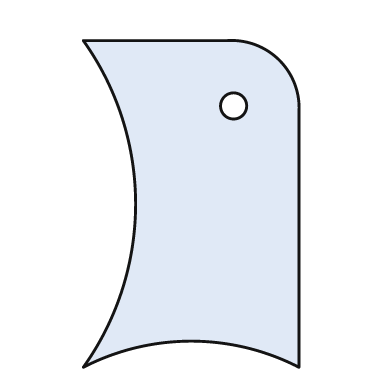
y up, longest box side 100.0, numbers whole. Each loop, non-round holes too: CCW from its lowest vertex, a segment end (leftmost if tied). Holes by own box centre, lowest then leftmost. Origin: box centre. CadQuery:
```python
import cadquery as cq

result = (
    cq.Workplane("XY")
    .moveTo(-33.0, -50.0)
    .threePointArc((0.0, -42.0), (33.0, -50.0))
    .lineTo(33.0, 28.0)
    .threePointArc((27.0, 44.0), (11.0, 50.0))
    .lineTo(-33.0, 50.0)
    .threePointArc((-17.0, 0.0), (-33.0, -50.0))
    .close()
    .moveTo(13.0, 30.0)
    .circle(4.0)
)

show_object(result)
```